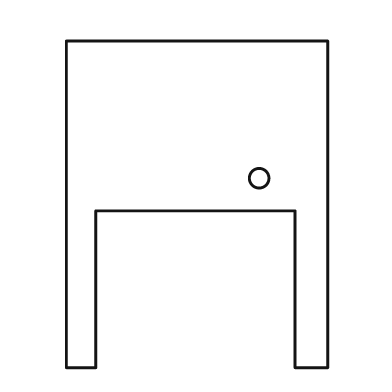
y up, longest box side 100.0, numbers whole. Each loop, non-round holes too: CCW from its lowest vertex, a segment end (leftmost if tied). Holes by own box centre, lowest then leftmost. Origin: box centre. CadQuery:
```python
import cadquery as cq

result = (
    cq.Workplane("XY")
    .moveTo(-40.0, -50.0)
    .lineTo(-31.0, -50.0)
    .lineTo(-31.0, -2.0)
    .lineTo(30.0, -2.0)
    .lineTo(30.0, -50.0)
    .lineTo(40.0, -50.0)
    .lineTo(40.0, 50.0)
    .lineTo(-40.0, 50.0)
    .close()
    .moveTo(19.0, 8.0)
    .circle(3.0)
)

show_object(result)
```